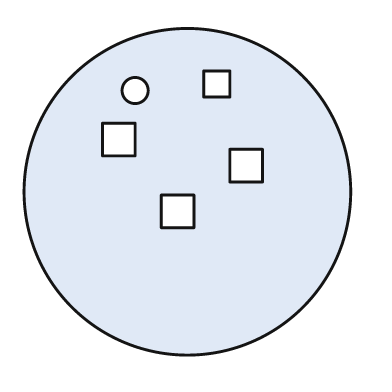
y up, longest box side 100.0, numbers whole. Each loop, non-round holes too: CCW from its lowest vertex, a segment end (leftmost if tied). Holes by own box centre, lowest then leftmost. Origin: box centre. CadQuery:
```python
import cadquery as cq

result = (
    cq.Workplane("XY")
    .moveTo(0.0, 0.0)
    .circle(50.0)
    .moveTo(-8.0, -11.0)
    .lineTo(2.0, -11.0)
    .lineTo(2.0, -1.0)
    .lineTo(-8.0, -1.0)
    .close()
    .moveTo(13.0, 3.0)
    .lineTo(23.0, 3.0)
    .lineTo(23.0, 13.0)
    .lineTo(13.0, 13.0)
    .close()
    .moveTo(-26.0, 11.0)
    .lineTo(-16.0, 11.0)
    .lineTo(-16.0, 21.0)
    .lineTo(-26.0, 21.0)
    .close()
    .moveTo(-16.0, 31.0)
    .circle(4.0)
    .moveTo(5.0, 29.0)
    .lineTo(13.0, 29.0)
    .lineTo(13.0, 37.0)
    .lineTo(5.0, 37.0)
    .close()
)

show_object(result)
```